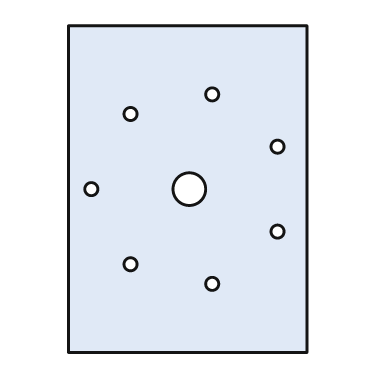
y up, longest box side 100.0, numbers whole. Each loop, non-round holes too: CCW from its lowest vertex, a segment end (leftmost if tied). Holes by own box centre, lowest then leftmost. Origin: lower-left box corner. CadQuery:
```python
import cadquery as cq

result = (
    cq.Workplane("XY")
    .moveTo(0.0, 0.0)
    .lineTo(73.0, 0.0)
    .lineTo(73.0, 100.0)
    .lineTo(0.0, 100.0)
    .close()
    .moveTo(44.0, 21.0)
    .circle(2.0)
    .moveTo(19.0, 27.0)
    .circle(2.0)
    .moveTo(64.0, 37.0)
    .circle(2.0)
    .moveTo(7.0, 50.0)
    .circle(2.0)
    .moveTo(37.0, 50.0)
    .circle(5.0)
    .moveTo(64.0, 63.0)
    .circle(2.0)
    .moveTo(19.0, 73.0)
    .circle(2.0)
    .moveTo(44.0, 79.0)
    .circle(2.0)
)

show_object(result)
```